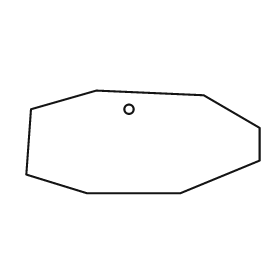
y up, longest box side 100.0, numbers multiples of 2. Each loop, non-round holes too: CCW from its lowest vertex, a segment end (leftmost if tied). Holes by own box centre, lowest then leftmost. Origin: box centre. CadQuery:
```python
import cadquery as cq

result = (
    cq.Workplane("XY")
    .moveTo(-24.0, -22.0)
    .lineTo(16.0, -22.0)
    .lineTo(50.0, -8.0)
    .lineTo(50.0, 6.0)
    .lineTo(26.0, 20.0)
    .lineTo(-20.0, 22.0)
    .lineTo(-48.0, 14.0)
    .lineTo(-50.0, -14.0)
    .close()
    .moveTo(-6.0, 14.0)
    .circle(2.0)
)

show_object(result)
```